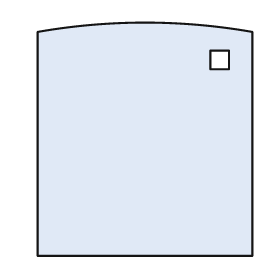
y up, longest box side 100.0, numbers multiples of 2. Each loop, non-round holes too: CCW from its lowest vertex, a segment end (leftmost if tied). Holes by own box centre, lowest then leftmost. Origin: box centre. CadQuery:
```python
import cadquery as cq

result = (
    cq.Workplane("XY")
    .moveTo(-46.0, -50.0)
    .lineTo(46.0, -50.0)
    .lineTo(46.0, 46.0)
    .threePointArc((0.0, 50.0), (-46.0, 46.0))
    .close()
    .moveTo(28.0, 30.0)
    .lineTo(36.0, 30.0)
    .lineTo(36.0, 38.0)
    .lineTo(28.0, 38.0)
    .close()
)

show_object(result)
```